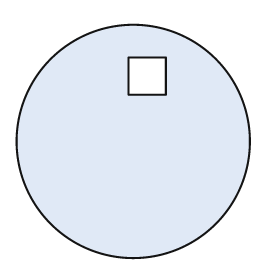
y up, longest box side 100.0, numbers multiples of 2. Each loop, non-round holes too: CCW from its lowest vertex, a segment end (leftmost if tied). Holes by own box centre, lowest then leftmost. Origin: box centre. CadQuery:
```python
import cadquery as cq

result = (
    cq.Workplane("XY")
    .moveTo(0.0, 0.0)
    .circle(50.0)
    .moveTo(-2.0, 20.0)
    .lineTo(14.0, 20.0)
    .lineTo(14.0, 36.0)
    .lineTo(-2.0, 36.0)
    .close()
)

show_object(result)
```